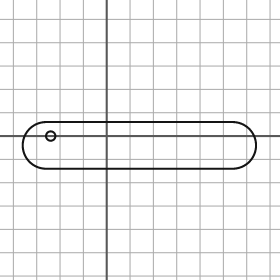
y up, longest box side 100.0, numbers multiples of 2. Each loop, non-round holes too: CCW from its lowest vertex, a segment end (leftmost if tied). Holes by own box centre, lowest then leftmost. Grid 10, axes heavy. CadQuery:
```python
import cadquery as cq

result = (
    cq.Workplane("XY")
    .moveTo(-26.0, -14.0)
    .lineTo(54.0, -14.0)
    .threePointArc((64.0, -4.0), (54.0, 6.0))
    .lineTo(-26.0, 6.0)
    .threePointArc((-36.0, -4.0), (-26.0, -14.0))
    .close()
    .moveTo(-24.0, 0.0)
    .circle(2.0)
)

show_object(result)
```